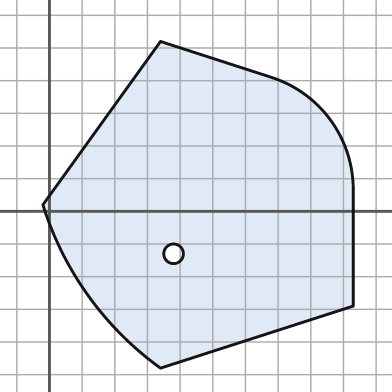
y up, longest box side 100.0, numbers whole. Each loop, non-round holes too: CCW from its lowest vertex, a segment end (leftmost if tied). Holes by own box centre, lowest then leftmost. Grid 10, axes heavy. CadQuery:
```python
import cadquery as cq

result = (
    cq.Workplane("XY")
    .moveTo(34.0, -48.0)
    .lineTo(93.0, -29.0)
    .lineTo(93.0, 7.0)
    .threePointArc((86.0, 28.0), (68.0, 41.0))
    .lineTo(34.0, 52.0)
    .lineTo(-2.0, 2.0)
    .threePointArc((12.0, -26.0), (34.0, -48.0))
    .close()
    .moveTo(38.0, -13.0)
    .circle(3.0)
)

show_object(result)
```